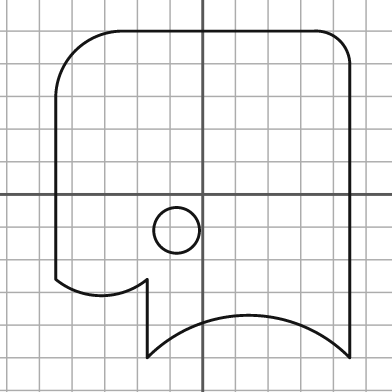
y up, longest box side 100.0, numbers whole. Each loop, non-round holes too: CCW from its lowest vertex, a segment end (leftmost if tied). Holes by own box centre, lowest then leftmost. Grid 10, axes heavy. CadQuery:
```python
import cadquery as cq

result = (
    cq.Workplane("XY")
    .moveTo(-17.0, -50.0)
    .threePointArc((14.0, -37.0), (45.0, -50.0))
    .lineTo(45.0, 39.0)
    .threePointArc((42.0, 47.0), (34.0, 50.0))
    .lineTo(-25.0, 50.0)
    .threePointArc((-39.0, 44.0), (-45.0, 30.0))
    .lineTo(-45.0, -26.0)
    .threePointArc((-31.0, -31.0), (-17.0, -26.0))
    .close()
    .moveTo(-8.0, -11.0)
    .circle(7.0)
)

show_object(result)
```